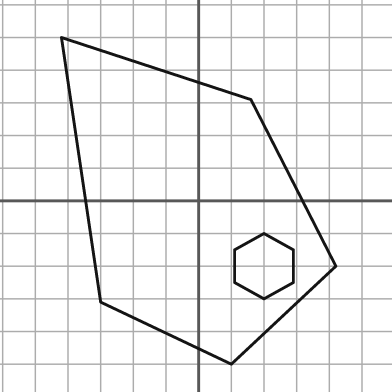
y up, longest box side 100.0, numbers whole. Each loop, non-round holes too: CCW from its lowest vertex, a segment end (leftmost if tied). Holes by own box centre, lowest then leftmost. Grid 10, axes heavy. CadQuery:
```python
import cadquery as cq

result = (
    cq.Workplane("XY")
    .moveTo(10.0, -50.0)
    .lineTo(42.0, -20.0)
    .lineTo(16.0, 31.0)
    .lineTo(-42.0, 50.0)
    .lineTo(-30.0, -31.0)
    .close()
    .moveTo(20.0, -30.0)
    .lineTo(29.0, -25.0)
    .lineTo(29.0, -15.0)
    .lineTo(20.0, -10.0)
    .lineTo(11.0, -15.0)
    .lineTo(11.0, -25.0)
    .close()
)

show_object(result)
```